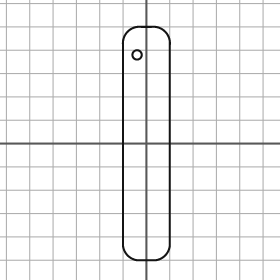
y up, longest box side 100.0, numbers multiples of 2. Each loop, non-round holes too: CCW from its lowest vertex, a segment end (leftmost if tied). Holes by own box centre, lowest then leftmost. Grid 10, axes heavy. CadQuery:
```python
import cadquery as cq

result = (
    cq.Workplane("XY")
    .moveTo(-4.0, -50.0)
    .lineTo(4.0, -50.0)
    .threePointArc((8.0, -48.0), (10.0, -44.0))
    .lineTo(10.0, 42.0)
    .threePointArc((8.0, 48.0), (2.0, 50.0))
    .lineTo(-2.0, 50.0)
    .threePointArc((-8.0, 48.0), (-10.0, 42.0))
    .lineTo(-10.0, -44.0)
    .threePointArc((-8.0, -48.0), (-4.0, -50.0))
    .close()
    .moveTo(-4.0, 38.0)
    .circle(2.0)
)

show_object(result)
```